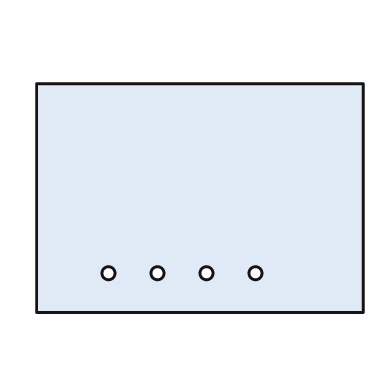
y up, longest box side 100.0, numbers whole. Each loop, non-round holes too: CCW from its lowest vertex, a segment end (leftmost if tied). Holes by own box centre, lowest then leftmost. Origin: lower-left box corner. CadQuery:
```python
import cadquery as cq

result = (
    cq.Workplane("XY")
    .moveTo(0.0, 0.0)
    .lineTo(100.0, 0.0)
    .lineTo(100.0, 70.0)
    .lineTo(0.0, 70.0)
    .close()
    .moveTo(22.0, 12.0)
    .circle(2.0)
    .moveTo(37.0, 12.0)
    .circle(2.0)
    .moveTo(52.0, 12.0)
    .circle(2.0)
    .moveTo(67.0, 12.0)
    .circle(2.0)
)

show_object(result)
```